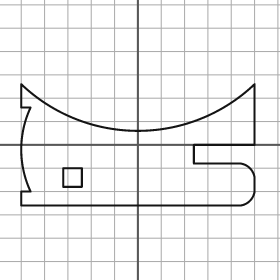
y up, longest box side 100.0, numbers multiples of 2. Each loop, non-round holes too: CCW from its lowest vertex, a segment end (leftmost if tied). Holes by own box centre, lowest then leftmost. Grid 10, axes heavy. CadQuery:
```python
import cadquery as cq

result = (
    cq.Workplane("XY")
    .moveTo(-50.0, -26.0)
    .lineTo(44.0, -26.0)
    .threePointArc((48.0, -24.0), (50.0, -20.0))
    .lineTo(50.0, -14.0)
    .threePointArc((48.0, -10.0), (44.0, -8.0))
    .lineTo(24.0, -8.0)
    .lineTo(24.0, 0.0)
    .lineTo(50.0, 0.0)
    .lineTo(50.0, 26.0)
    .threePointArc((0.0, 6.0), (-50.0, 26.0))
    .lineTo(-50.0, 16.0)
    .lineTo(-46.0, 16.0)
    .threePointArc((-50.0, -2.0), (-46.0, -20.0))
    .lineTo(-50.0, -20.0)
    .close()
    .moveTo(-32.0, -18.0)
    .lineTo(-24.0, -18.0)
    .lineTo(-24.0, -10.0)
    .lineTo(-32.0, -10.0)
    .close()
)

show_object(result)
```